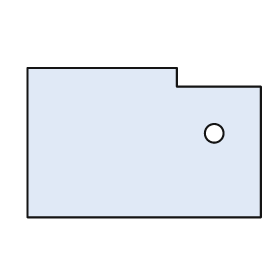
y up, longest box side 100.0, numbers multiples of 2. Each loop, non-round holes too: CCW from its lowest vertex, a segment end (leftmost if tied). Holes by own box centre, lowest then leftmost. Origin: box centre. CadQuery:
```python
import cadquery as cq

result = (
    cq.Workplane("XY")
    .moveTo(-50.0, -32.0)
    .lineTo(50.0, -32.0)
    .lineTo(50.0, 24.0)
    .lineTo(14.0, 24.0)
    .lineTo(14.0, 32.0)
    .lineTo(-50.0, 32.0)
    .close()
    .moveTo(30.0, 4.0)
    .circle(4.0)
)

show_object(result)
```